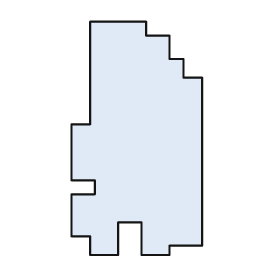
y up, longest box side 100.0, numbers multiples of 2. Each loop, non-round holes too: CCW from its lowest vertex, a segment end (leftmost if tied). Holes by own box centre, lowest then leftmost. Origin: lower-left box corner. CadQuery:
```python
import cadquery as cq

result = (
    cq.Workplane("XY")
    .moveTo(8.0, 0.0)
    .lineTo(20.0, 0.0)
    .lineTo(20.0, 14.0)
    .lineTo(30.0, 14.0)
    .lineTo(30.0, 0.0)
    .lineTo(42.0, 0.0)
    .lineTo(42.0, 4.0)
    .lineTo(56.0, 4.0)
    .lineTo(56.0, 76.0)
    .lineTo(48.0, 76.0)
    .lineTo(48.0, 84.0)
    .lineTo(42.0, 84.0)
    .lineTo(42.0, 94.0)
    .lineTo(32.0, 94.0)
    .lineTo(32.0, 100.0)
    .lineTo(8.0, 100.0)
    .lineTo(8.0, 56.0)
    .lineTo(0.0, 56.0)
    .lineTo(0.0, 32.0)
    .lineTo(10.0, 32.0)
    .lineTo(10.0, 26.0)
    .lineTo(0.0, 26.0)
    .lineTo(0.0, 8.0)
    .lineTo(8.0, 8.0)
    .close()
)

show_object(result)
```